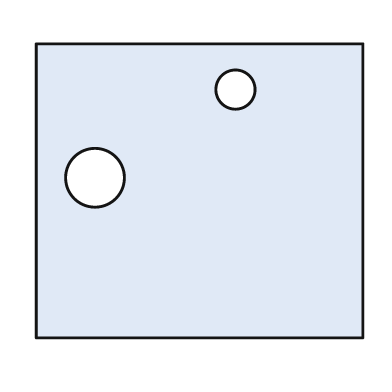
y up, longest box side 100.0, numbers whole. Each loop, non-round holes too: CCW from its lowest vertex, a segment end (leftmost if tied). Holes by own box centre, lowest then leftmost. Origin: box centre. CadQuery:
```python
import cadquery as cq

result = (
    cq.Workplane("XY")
    .moveTo(-50.0, -45.0)
    .lineTo(50.0, -45.0)
    .lineTo(50.0, 45.0)
    .lineTo(-50.0, 45.0)
    .close()
    .moveTo(-32.0, 4.0)
    .circle(9.0)
    .moveTo(11.0, 31.0)
    .circle(6.0)
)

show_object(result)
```